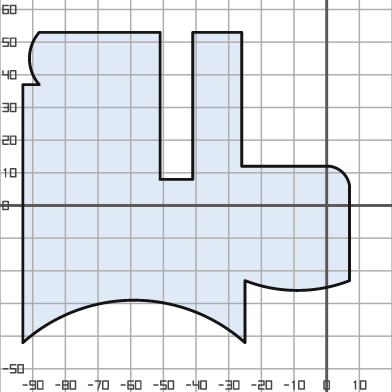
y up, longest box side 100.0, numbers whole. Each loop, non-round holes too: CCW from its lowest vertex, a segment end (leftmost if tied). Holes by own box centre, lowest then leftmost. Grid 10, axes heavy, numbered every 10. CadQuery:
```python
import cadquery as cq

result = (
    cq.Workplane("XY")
    .moveTo(-93.0, -42.0)
    .threePointArc((-59.0, -29.0), (-25.0, -42.0))
    .lineTo(-25.0, -23.0)
    .threePointArc((-9.0, -26.0), (7.0, -23.0))
    .lineTo(7.0, 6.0)
    .threePointArc((5.0, 10.0), (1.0, 12.0))
    .lineTo(-26.0, 12.0)
    .lineTo(-26.0, 53.0)
    .lineTo(-41.0, 53.0)
    .lineTo(-41.0, 8.0)
    .lineTo(-51.0, 8.0)
    .lineTo(-51.0, 53.0)
    .lineTo(-88.0, 53.0)
    .threePointArc((-91.0, 45.0), (-88.0, 37.0))
    .lineTo(-93.0, 37.0)
    .close()
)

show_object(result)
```